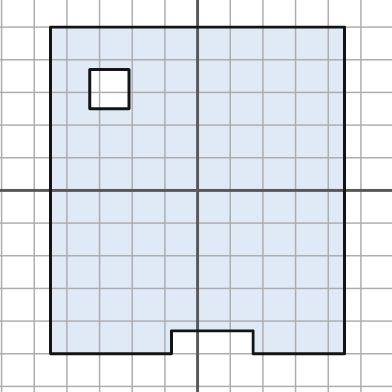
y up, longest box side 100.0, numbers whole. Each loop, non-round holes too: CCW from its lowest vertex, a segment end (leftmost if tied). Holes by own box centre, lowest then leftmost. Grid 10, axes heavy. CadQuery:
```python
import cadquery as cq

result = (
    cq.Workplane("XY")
    .moveTo(-45.0, -50.0)
    .lineTo(-8.0, -50.0)
    .lineTo(-8.0, -43.0)
    .lineTo(17.0, -43.0)
    .lineTo(17.0, -50.0)
    .lineTo(45.0, -50.0)
    .lineTo(45.0, 50.0)
    .lineTo(-45.0, 50.0)
    .close()
    .moveTo(-33.0, 25.0)
    .lineTo(-21.0, 25.0)
    .lineTo(-21.0, 37.0)
    .lineTo(-33.0, 37.0)
    .close()
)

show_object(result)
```